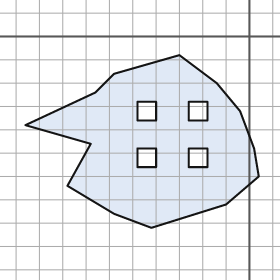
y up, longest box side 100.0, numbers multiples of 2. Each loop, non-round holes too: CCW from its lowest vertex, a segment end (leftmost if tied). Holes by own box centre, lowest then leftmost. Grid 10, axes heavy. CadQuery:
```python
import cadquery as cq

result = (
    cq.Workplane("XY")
    .moveTo(-42.0, -82.0)
    .lineTo(-10.0, -72.0)
    .lineTo(4.0, -60.0)
    .lineTo(2.0, -48.0)
    .lineTo(-4.0, -32.0)
    .lineTo(-14.0, -20.0)
    .lineTo(-30.0, -8.0)
    .lineTo(-58.0, -16.0)
    .lineTo(-66.0, -24.0)
    .lineTo(-96.0, -38.0)
    .lineTo(-68.0, -46.0)
    .lineTo(-78.0, -64.0)
    .lineTo(-58.0, -76.0)
    .close()
    .moveTo(-48.0, -56.0)
    .lineTo(-40.0, -56.0)
    .lineTo(-40.0, -48.0)
    .lineTo(-48.0, -48.0)
    .close()
    .moveTo(-26.0, -56.0)
    .lineTo(-18.0, -56.0)
    .lineTo(-18.0, -48.0)
    .lineTo(-26.0, -48.0)
    .close()
    .moveTo(-48.0, -36.0)
    .lineTo(-40.0, -36.0)
    .lineTo(-40.0, -28.0)
    .lineTo(-48.0, -28.0)
    .close()
    .moveTo(-26.0, -36.0)
    .lineTo(-18.0, -36.0)
    .lineTo(-18.0, -28.0)
    .lineTo(-26.0, -28.0)
    .close()
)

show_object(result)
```